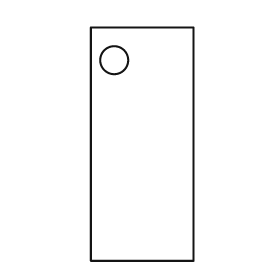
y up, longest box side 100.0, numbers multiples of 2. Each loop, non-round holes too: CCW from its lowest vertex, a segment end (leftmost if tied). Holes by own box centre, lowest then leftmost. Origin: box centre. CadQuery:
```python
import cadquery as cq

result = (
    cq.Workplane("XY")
    .moveTo(-22.0, -50.0)
    .lineTo(22.0, -50.0)
    .lineTo(22.0, 50.0)
    .lineTo(-22.0, 50.0)
    .close()
    .moveTo(-12.0, 36.0)
    .circle(6.0)
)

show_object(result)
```